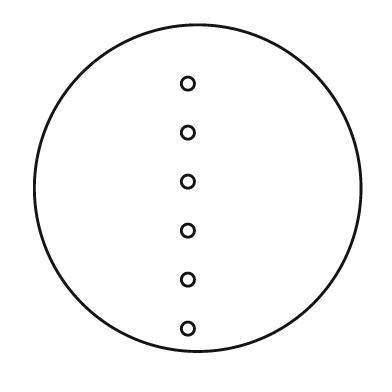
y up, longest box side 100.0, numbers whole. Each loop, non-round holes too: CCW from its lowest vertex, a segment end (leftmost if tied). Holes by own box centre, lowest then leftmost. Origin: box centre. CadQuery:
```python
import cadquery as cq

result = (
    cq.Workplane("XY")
    .moveTo(0.0, 0.0)
    .circle(50.0)
    .moveTo(-3.0, -43.0)
    .circle(2.0)
    .moveTo(-3.0, -28.0)
    .circle(2.0)
    .moveTo(-3.0, -13.0)
    .circle(2.0)
    .moveTo(-3.0, 2.0)
    .circle(2.0)
    .moveTo(-3.0, 17.0)
    .circle(2.0)
    .moveTo(-3.0, 32.0)
    .circle(2.0)
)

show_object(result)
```